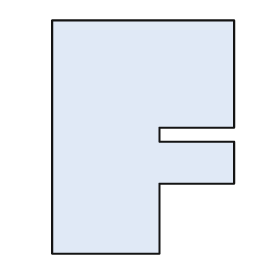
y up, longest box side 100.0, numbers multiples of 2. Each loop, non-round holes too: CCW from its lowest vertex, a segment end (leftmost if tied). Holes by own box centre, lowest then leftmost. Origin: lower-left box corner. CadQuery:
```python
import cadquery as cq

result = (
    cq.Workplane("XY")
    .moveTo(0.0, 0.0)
    .lineTo(46.0, 0.0)
    .lineTo(46.0, 30.0)
    .lineTo(78.0, 30.0)
    .lineTo(78.0, 48.0)
    .lineTo(46.0, 48.0)
    .lineTo(46.0, 54.0)
    .lineTo(78.0, 54.0)
    .lineTo(78.0, 100.0)
    .lineTo(0.0, 100.0)
    .close()
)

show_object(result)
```